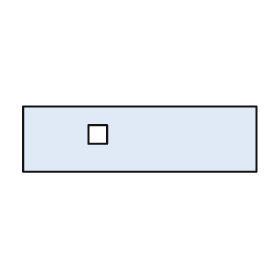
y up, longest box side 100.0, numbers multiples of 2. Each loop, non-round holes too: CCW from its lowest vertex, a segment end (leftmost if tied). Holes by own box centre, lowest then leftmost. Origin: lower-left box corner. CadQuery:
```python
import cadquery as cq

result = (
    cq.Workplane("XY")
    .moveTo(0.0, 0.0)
    .lineTo(100.0, 0.0)
    .lineTo(100.0, 28.0)
    .lineTo(0.0, 28.0)
    .close()
    .moveTo(28.0, 12.0)
    .lineTo(36.0, 12.0)
    .lineTo(36.0, 20.0)
    .lineTo(28.0, 20.0)
    .close()
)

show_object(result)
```